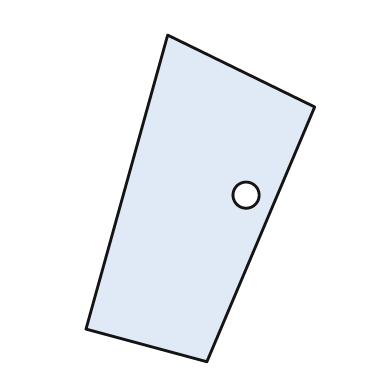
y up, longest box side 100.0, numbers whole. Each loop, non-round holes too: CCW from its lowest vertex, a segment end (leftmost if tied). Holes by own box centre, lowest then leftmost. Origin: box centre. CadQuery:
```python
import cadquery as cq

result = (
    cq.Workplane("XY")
    .moveTo(2.0, -50.0)
    .lineTo(35.0, 28.0)
    .lineTo(-10.0, 50.0)
    .lineTo(-35.0, -40.0)
    .close()
    .moveTo(14.0, 1.0)
    .circle(4.0)
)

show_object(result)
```